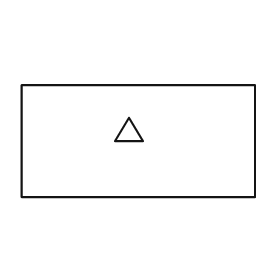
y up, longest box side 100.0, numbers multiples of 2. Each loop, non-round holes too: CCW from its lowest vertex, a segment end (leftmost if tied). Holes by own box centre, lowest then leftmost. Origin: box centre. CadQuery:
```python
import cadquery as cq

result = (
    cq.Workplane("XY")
    .moveTo(-50.0, -24.0)
    .lineTo(50.0, -24.0)
    .lineTo(50.0, 24.0)
    .lineTo(-50.0, 24.0)
    .close()
    .moveTo(-10.0, 0.0)
    .lineTo(2.0, 0.0)
    .lineTo(-4.0, 10.0)
    .close()
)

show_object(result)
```